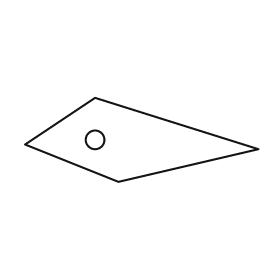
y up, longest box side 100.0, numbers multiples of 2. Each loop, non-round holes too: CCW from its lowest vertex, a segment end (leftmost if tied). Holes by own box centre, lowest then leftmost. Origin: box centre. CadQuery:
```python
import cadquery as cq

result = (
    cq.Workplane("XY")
    .moveTo(-10.0, -18.0)
    .lineTo(50.0, -4.0)
    .lineTo(-20.0, 18.0)
    .lineTo(-50.0, -2.0)
    .close()
    .moveTo(-20.0, 0.0)
    .circle(4.0)
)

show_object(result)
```